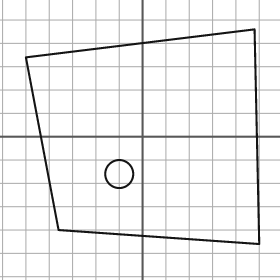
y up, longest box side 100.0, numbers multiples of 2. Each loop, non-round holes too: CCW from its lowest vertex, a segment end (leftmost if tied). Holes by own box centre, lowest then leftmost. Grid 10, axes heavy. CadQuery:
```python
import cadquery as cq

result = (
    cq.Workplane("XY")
    .moveTo(50.0, -46.0)
    .lineTo(48.0, 46.0)
    .lineTo(-50.0, 34.0)
    .lineTo(-36.0, -40.0)
    .close()
    .moveTo(-10.0, -16.0)
    .circle(6.0)
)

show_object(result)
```